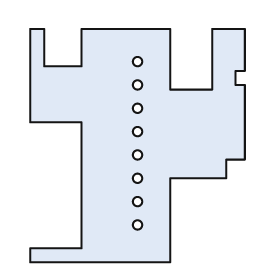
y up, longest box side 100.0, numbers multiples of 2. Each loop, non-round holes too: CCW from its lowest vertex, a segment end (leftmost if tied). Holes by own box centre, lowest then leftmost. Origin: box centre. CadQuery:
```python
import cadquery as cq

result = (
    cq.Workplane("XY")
    .moveTo(-46.0, -50.0)
    .lineTo(14.0, -50.0)
    .lineTo(14.0, -14.0)
    .lineTo(38.0, -14.0)
    .lineTo(38.0, -6.0)
    .lineTo(46.0, -6.0)
    .lineTo(46.0, 26.0)
    .lineTo(42.0, 26.0)
    .lineTo(42.0, 32.0)
    .lineTo(46.0, 32.0)
    .lineTo(46.0, 50.0)
    .lineTo(32.0, 50.0)
    .lineTo(32.0, 24.0)
    .lineTo(14.0, 24.0)
    .lineTo(14.0, 50.0)
    .lineTo(-24.0, 50.0)
    .lineTo(-24.0, 34.0)
    .lineTo(-40.0, 34.0)
    .lineTo(-40.0, 50.0)
    .lineTo(-46.0, 50.0)
    .lineTo(-46.0, 10.0)
    .lineTo(-24.0, 10.0)
    .lineTo(-24.0, -44.0)
    .lineTo(-46.0, -44.0)
    .close()
    .moveTo(0.0, -34.0)
    .circle(2.0)
    .moveTo(0.0, -24.0)
    .circle(2.0)
    .moveTo(0.0, -14.0)
    .circle(2.0)
    .moveTo(0.0, -4.0)
    .circle(2.0)
    .moveTo(0.0, 6.0)
    .circle(2.0)
    .moveTo(0.0, 16.0)
    .circle(2.0)
    .moveTo(0.0, 26.0)
    .circle(2.0)
    .moveTo(0.0, 36.0)
    .circle(2.0)
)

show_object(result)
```